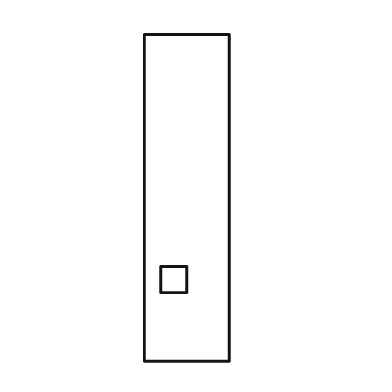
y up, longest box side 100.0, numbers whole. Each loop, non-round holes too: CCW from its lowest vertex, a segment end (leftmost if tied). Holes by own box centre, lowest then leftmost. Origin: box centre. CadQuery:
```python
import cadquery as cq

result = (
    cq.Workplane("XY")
    .moveTo(-13.0, -50.0)
    .lineTo(13.0, -50.0)
    .lineTo(13.0, 50.0)
    .lineTo(-13.0, 50.0)
    .close()
    .moveTo(-8.0, -29.0)
    .lineTo(0.0, -29.0)
    .lineTo(0.0, -21.0)
    .lineTo(-8.0, -21.0)
    .close()
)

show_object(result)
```